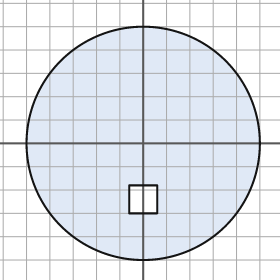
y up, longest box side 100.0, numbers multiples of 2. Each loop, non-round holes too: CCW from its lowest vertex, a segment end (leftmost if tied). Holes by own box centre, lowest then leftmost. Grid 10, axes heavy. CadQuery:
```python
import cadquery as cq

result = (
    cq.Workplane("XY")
    .moveTo(0.0, 0.0)
    .circle(50.0)
    .moveTo(-6.0, -30.0)
    .lineTo(6.0, -30.0)
    .lineTo(6.0, -18.0)
    .lineTo(-6.0, -18.0)
    .close()
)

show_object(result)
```